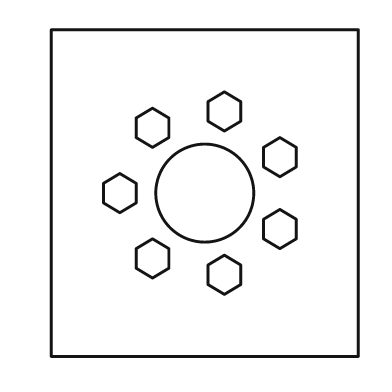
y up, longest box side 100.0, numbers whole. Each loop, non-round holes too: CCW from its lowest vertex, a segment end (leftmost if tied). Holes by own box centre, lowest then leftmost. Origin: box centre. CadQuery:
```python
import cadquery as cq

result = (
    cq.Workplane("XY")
    .moveTo(-47.0, -50.0)
    .lineTo(47.0, -50.0)
    .lineTo(47.0, 50.0)
    .lineTo(-47.0, 50.0)
    .close()
    .moveTo(6.0, -31.0)
    .lineTo(11.0, -28.0)
    .lineTo(11.0, -22.0)
    .lineTo(6.0, -19.0)
    .lineTo(1.0, -22.0)
    .lineTo(1.0, -28.0)
    .close()
    .moveTo(-16.0, -26.0)
    .lineTo(-11.0, -23.0)
    .lineTo(-11.0, -17.0)
    .lineTo(-16.0, -14.0)
    .lineTo(-21.0, -17.0)
    .lineTo(-21.0, -23.0)
    .close()
    .moveTo(23.0, -17.0)
    .lineTo(28.0, -14.0)
    .lineTo(28.0, -8.0)
    .lineTo(23.0, -5.0)
    .lineTo(18.0, -8.0)
    .lineTo(18.0, -14.0)
    .close()
    .moveTo(-26.0, -6.0)
    .lineTo(-21.0, -3.0)
    .lineTo(-21.0, 3.0)
    .lineTo(-26.0, 6.0)
    .lineTo(-31.0, 3.0)
    .lineTo(-31.0, -3.0)
    .close()
    .moveTo(0.0, 0.0)
    .circle(15.0)
    .moveTo(23.0, 5.0)
    .lineTo(28.0, 8.0)
    .lineTo(28.0, 14.0)
    .lineTo(23.0, 17.0)
    .lineTo(18.0, 14.0)
    .lineTo(18.0, 8.0)
    .close()
    .moveTo(-16.0, 14.0)
    .lineTo(-11.0, 17.0)
    .lineTo(-11.0, 23.0)
    .lineTo(-16.0, 26.0)
    .lineTo(-21.0, 23.0)
    .lineTo(-21.0, 17.0)
    .close()
    .moveTo(6.0, 19.0)
    .lineTo(11.0, 22.0)
    .lineTo(11.0, 28.0)
    .lineTo(6.0, 31.0)
    .lineTo(1.0, 28.0)
    .lineTo(1.0, 22.0)
    .close()
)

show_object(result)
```